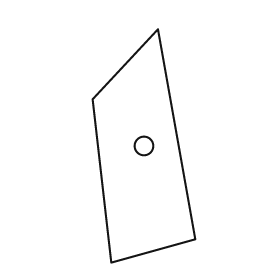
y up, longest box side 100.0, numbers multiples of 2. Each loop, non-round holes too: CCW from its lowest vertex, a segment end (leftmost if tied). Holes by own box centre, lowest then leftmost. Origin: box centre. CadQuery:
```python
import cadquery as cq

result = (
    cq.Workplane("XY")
    .moveTo(-14.0, -50.0)
    .lineTo(22.0, -40.0)
    .lineTo(6.0, 50.0)
    .lineTo(-22.0, 20.0)
    .close()
    .moveTo(0.0, 0.0)
    .circle(4.0)
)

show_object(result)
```